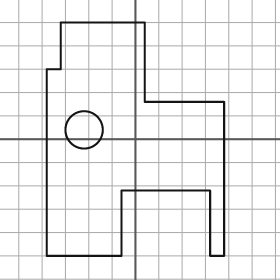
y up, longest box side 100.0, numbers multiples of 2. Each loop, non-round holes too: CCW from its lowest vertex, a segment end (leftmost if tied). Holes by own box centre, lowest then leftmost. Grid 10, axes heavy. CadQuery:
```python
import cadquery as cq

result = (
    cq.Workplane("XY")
    .moveTo(-38.0, -50.0)
    .lineTo(-6.0, -50.0)
    .lineTo(-6.0, -22.0)
    .lineTo(32.0, -22.0)
    .lineTo(32.0, -50.0)
    .lineTo(38.0, -50.0)
    .lineTo(38.0, 16.0)
    .lineTo(4.0, 16.0)
    .lineTo(4.0, 50.0)
    .lineTo(-32.0, 50.0)
    .lineTo(-32.0, 30.0)
    .lineTo(-38.0, 30.0)
    .close()
    .moveTo(-22.0, 4.0)
    .circle(8.0)
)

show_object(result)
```